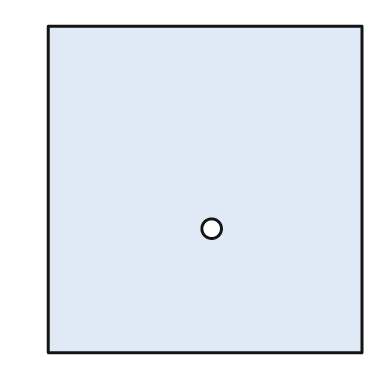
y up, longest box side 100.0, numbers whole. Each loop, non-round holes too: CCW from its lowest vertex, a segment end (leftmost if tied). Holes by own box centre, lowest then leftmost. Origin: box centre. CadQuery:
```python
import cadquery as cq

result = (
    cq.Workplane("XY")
    .moveTo(-48.0, -50.0)
    .lineTo(48.0, -50.0)
    .lineTo(48.0, 50.0)
    .lineTo(-48.0, 50.0)
    .close()
    .moveTo(2.0, -12.0)
    .circle(3.0)
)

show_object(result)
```